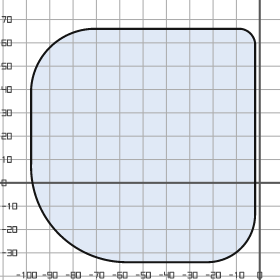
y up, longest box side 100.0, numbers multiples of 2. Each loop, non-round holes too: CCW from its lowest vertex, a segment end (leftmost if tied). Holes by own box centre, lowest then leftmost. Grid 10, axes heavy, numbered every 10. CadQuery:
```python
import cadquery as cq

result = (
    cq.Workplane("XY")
    .moveTo(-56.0, -34.0)
    .lineTo(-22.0, -34.0)
    .threePointArc((-8.0, -28.0), (-2.0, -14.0))
    .lineTo(-2.0, 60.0)
    .threePointArc((-4.0, 64.0), (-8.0, 66.0))
    .lineTo(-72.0, 66.0)
    .threePointArc((-90.0, 58.0), (-98.0, 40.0))
    .lineTo(-98.0, 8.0)
    .threePointArc((-86.0, -22.0), (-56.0, -34.0))
    .close()
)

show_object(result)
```